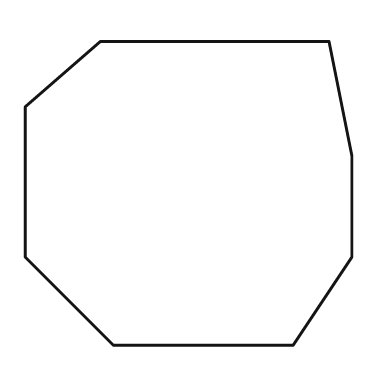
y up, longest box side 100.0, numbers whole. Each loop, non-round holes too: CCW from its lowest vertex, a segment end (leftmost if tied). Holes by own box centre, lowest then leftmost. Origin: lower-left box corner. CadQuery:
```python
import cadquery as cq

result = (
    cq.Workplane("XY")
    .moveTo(27.0, 0.0)
    .lineTo(82.0, 0.0)
    .lineTo(100.0, 27.0)
    .lineTo(100.0, 58.0)
    .lineTo(93.0, 93.0)
    .lineTo(23.0, 93.0)
    .lineTo(0.0, 73.0)
    .lineTo(0.0, 27.0)
    .close()
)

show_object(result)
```